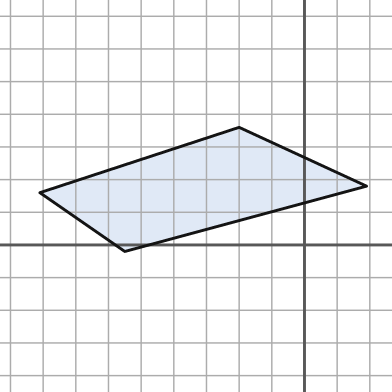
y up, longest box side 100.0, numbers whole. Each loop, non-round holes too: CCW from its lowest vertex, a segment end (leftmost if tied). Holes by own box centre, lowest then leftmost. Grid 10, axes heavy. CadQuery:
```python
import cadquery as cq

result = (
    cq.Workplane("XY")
    .moveTo(-55.0, -2.0)
    .lineTo(19.0, 18.0)
    .lineTo(-20.0, 36.0)
    .lineTo(-81.0, 16.0)
    .close()
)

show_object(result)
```